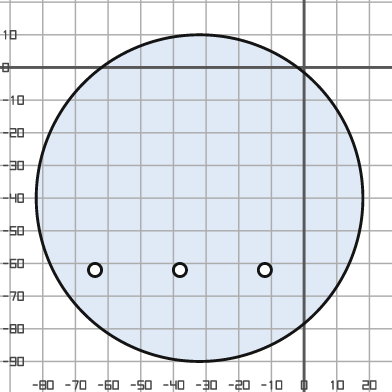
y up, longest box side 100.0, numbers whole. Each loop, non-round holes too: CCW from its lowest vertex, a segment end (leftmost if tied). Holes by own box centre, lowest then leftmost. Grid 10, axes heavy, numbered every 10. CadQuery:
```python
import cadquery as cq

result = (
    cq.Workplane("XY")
    .moveTo(-32.0, -40.0)
    .circle(50.0)
    .moveTo(-64.0, -62.0)
    .circle(2.0)
    .moveTo(-38.0, -62.0)
    .circle(2.0)
    .moveTo(-12.0, -62.0)
    .circle(2.0)
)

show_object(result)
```